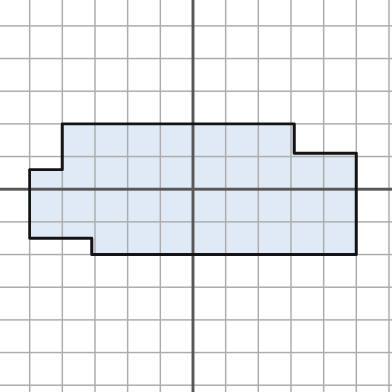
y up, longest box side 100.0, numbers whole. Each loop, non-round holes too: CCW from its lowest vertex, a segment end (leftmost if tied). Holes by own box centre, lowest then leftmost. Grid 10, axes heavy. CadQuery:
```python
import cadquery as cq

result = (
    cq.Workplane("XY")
    .moveTo(-31.0, -20.0)
    .lineTo(50.0, -20.0)
    .lineTo(50.0, 11.0)
    .lineTo(31.0, 11.0)
    .lineTo(31.0, 20.0)
    .lineTo(-40.0, 20.0)
    .lineTo(-40.0, 6.0)
    .lineTo(-50.0, 6.0)
    .lineTo(-50.0, -15.0)
    .lineTo(-31.0, -15.0)
    .close()
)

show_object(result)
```